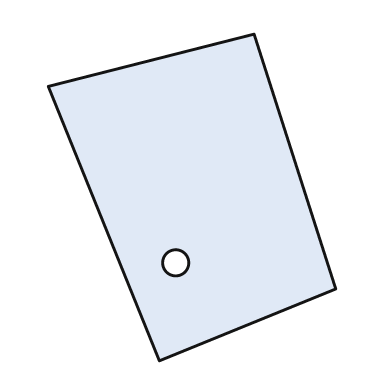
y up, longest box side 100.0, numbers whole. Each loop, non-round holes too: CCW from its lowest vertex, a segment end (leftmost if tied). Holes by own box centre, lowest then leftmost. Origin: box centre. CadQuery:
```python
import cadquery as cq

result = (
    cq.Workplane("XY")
    .moveTo(-10.0, -50.0)
    .lineTo(44.0, -28.0)
    .lineTo(19.0, 50.0)
    .lineTo(-44.0, 34.0)
    .close()
    .moveTo(-5.0, -20.0)
    .circle(4.0)
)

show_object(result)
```